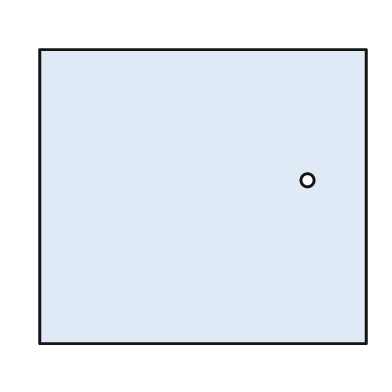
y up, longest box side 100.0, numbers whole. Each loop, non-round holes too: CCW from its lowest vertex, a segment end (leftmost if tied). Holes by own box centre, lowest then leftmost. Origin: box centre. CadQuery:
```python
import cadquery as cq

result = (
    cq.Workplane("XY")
    .moveTo(-50.0, -45.0)
    .lineTo(50.0, -45.0)
    .lineTo(50.0, 45.0)
    .lineTo(-50.0, 45.0)
    .close()
    .moveTo(32.0, 5.0)
    .circle(2.0)
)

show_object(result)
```